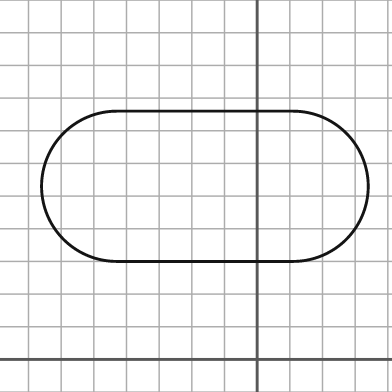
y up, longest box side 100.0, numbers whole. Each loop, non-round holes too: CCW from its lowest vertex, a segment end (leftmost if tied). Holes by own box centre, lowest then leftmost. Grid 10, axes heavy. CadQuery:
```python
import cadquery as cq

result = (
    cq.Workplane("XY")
    .moveTo(-43.0, 30.0)
    .lineTo(11.0, 30.0)
    .threePointArc((34.0, 53.0), (11.0, 76.0))
    .lineTo(-43.0, 76.0)
    .threePointArc((-66.0, 53.0), (-43.0, 30.0))
    .close()
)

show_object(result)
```